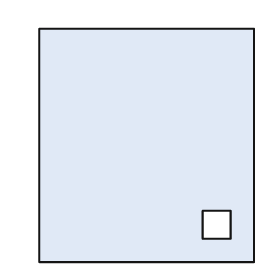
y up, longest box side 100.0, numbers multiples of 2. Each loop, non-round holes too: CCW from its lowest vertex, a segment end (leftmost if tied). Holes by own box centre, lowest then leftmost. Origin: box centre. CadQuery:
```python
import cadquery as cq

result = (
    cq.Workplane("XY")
    .moveTo(-46.0, -50.0)
    .lineTo(46.0, -50.0)
    .lineTo(46.0, 50.0)
    .lineTo(-46.0, 50.0)
    .close()
    .moveTo(24.0, -40.0)
    .lineTo(36.0, -40.0)
    .lineTo(36.0, -28.0)
    .lineTo(24.0, -28.0)
    .close()
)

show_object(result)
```